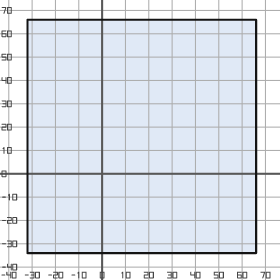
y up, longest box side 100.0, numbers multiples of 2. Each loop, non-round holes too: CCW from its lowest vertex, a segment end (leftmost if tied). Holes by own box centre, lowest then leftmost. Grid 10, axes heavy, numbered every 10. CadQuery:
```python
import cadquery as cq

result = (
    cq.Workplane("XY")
    .moveTo(-32.0, -34.0)
    .lineTo(66.0, -34.0)
    .lineTo(66.0, 66.0)
    .lineTo(-32.0, 66.0)
    .close()
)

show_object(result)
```